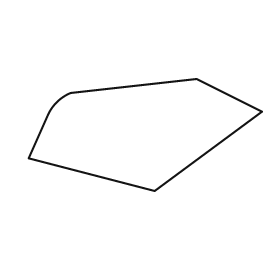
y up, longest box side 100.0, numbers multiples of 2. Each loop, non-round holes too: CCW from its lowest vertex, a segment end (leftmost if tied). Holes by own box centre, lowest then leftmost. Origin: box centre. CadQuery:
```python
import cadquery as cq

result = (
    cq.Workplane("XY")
    .moveTo(4.0, -24.0)
    .lineTo(50.0, 10.0)
    .lineTo(22.0, 24.0)
    .lineTo(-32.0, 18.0)
    .threePointArc((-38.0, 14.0), (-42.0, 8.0))
    .lineTo(-50.0, -10.0)
    .close()
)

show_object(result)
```